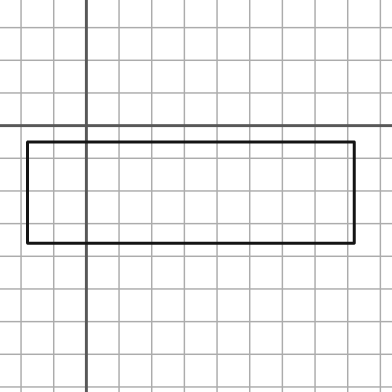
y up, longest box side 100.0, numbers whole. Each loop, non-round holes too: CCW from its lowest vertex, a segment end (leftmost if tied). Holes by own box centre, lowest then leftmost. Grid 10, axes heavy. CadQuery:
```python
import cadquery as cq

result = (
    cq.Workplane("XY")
    .moveTo(-18.0, -36.0)
    .lineTo(82.0, -36.0)
    .lineTo(82.0, -5.0)
    .lineTo(-18.0, -5.0)
    .close()
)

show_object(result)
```